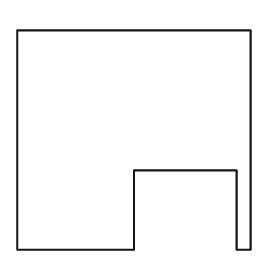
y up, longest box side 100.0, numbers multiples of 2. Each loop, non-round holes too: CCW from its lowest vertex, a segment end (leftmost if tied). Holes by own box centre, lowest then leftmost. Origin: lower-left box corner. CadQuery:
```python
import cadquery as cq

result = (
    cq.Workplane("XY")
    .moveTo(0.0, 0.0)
    .lineTo(50.0, 0.0)
    .lineTo(50.0, 34.0)
    .lineTo(94.0, 34.0)
    .lineTo(94.0, 0.0)
    .lineTo(100.0, 0.0)
    .lineTo(100.0, 94.0)
    .lineTo(0.0, 94.0)
    .close()
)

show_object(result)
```